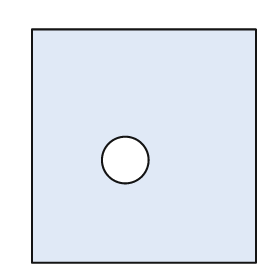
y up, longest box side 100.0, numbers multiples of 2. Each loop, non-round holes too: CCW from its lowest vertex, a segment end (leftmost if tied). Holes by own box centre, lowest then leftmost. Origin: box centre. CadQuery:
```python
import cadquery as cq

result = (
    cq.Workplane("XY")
    .moveTo(-48.0, -50.0)
    .lineTo(48.0, -50.0)
    .lineTo(48.0, 50.0)
    .lineTo(-48.0, 50.0)
    .close()
    .moveTo(-8.0, -6.0)
    .circle(10.0)
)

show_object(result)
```